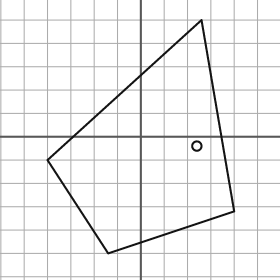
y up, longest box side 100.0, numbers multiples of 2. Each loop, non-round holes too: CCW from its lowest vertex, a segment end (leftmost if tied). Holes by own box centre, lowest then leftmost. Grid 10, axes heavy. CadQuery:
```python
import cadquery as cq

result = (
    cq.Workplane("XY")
    .moveTo(-14.0, -50.0)
    .lineTo(40.0, -32.0)
    .lineTo(26.0, 50.0)
    .lineTo(-40.0, -10.0)
    .close()
    .moveTo(24.0, -4.0)
    .circle(2.0)
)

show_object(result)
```